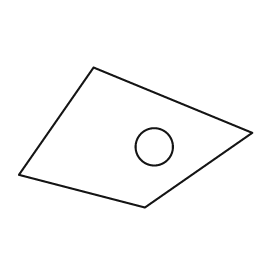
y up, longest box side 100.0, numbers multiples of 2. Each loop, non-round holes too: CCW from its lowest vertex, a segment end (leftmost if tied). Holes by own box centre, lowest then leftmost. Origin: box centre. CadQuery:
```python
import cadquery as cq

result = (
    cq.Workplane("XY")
    .moveTo(4.0, -30.0)
    .lineTo(50.0, 2.0)
    .lineTo(-18.0, 30.0)
    .lineTo(-50.0, -16.0)
    .close()
    .moveTo(8.0, -4.0)
    .circle(8.0)
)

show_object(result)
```